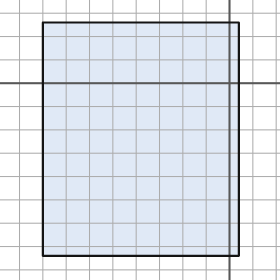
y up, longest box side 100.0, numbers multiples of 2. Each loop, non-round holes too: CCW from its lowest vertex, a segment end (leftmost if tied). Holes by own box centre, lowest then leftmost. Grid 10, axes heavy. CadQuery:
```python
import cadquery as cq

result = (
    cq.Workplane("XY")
    .moveTo(-80.0, -74.0)
    .lineTo(4.0, -74.0)
    .lineTo(4.0, 26.0)
    .lineTo(-80.0, 26.0)
    .close()
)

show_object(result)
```